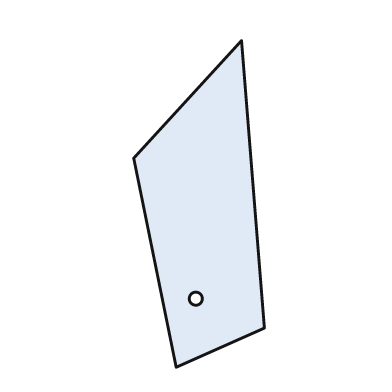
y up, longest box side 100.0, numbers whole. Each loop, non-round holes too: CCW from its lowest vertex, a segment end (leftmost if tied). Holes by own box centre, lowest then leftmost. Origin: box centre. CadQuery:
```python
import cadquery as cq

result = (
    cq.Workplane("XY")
    .moveTo(-7.0, -50.0)
    .lineTo(20.0, -38.0)
    .lineTo(13.0, 50.0)
    .lineTo(-20.0, 14.0)
    .close()
    .moveTo(-1.0, -29.0)
    .circle(2.0)
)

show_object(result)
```